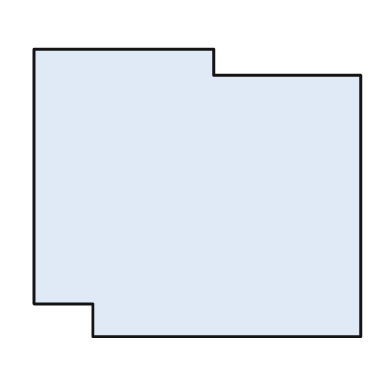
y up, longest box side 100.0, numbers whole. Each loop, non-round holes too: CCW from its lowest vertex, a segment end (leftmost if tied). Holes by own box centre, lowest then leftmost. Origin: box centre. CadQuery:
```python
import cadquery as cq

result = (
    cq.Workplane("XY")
    .moveTo(-32.0, -44.0)
    .lineTo(50.0, -44.0)
    .lineTo(50.0, 36.0)
    .lineTo(5.0, 36.0)
    .lineTo(5.0, 44.0)
    .lineTo(-50.0, 44.0)
    .lineTo(-50.0, -34.0)
    .lineTo(-32.0, -34.0)
    .close()
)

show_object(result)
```